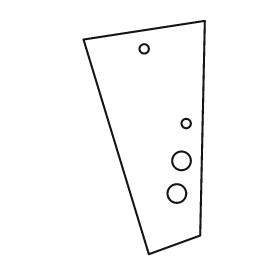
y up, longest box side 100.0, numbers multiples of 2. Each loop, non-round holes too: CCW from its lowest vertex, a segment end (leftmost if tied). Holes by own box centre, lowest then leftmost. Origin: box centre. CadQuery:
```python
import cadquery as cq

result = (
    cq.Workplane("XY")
    .moveTo(2.0, -50.0)
    .lineTo(24.0, -42.0)
    .lineTo(26.0, 50.0)
    .lineTo(-26.0, 42.0)
    .close()
    .moveTo(14.0, -24.0)
    .circle(4.0)
    .moveTo(16.0, -10.0)
    .circle(4.0)
    .moveTo(18.0, 6.0)
    .circle(2.0)
    .moveTo(0.0, 38.0)
    .circle(2.0)
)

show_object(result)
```